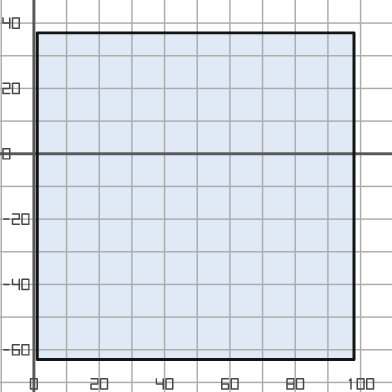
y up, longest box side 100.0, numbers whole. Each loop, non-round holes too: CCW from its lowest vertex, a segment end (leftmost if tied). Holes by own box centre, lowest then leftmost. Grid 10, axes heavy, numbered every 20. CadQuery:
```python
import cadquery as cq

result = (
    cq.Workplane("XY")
    .moveTo(1.0, -63.0)
    .lineTo(98.0, -63.0)
    .lineTo(98.0, 37.0)
    .lineTo(1.0, 37.0)
    .close()
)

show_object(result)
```